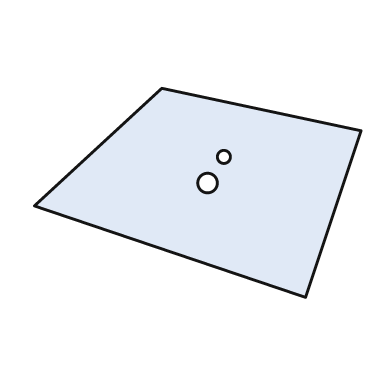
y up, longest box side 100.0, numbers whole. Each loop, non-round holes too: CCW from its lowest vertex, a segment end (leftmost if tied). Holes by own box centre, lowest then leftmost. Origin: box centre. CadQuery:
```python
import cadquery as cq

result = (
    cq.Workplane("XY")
    .moveTo(33.0, -32.0)
    .lineTo(50.0, 19.0)
    .lineTo(-11.0, 32.0)
    .lineTo(-50.0, -4.0)
    .close()
    .moveTo(3.0, 3.0)
    .circle(3.0)
    .moveTo(8.0, 11.0)
    .circle(2.0)
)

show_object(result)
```